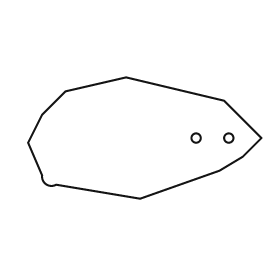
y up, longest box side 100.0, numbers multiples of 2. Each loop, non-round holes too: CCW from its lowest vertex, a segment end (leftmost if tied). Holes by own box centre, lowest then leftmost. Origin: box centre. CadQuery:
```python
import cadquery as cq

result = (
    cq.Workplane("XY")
    .moveTo(-2.0, -26.0)
    .lineTo(32.0, -14.0)
    .lineTo(42.0, -8.0)
    .lineTo(50.0, 0.0)
    .lineTo(34.0, 16.0)
    .lineTo(-8.0, 26.0)
    .lineTo(-34.0, 20.0)
    .lineTo(-44.0, 10.0)
    .lineTo(-50.0, -2.0)
    .lineTo(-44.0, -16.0)
    .threePointArc((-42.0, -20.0), (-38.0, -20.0))
    .close()
    .moveTo(22.0, 0.0)
    .circle(2.0)
    .moveTo(36.0, 0.0)
    .circle(2.0)
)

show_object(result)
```